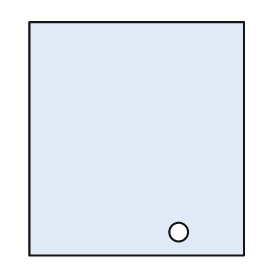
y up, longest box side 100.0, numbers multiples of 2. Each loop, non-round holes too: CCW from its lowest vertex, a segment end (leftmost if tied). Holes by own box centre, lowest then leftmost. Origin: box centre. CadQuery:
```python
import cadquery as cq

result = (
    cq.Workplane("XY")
    .moveTo(-46.0, -50.0)
    .lineTo(46.0, -50.0)
    .lineTo(46.0, 50.0)
    .lineTo(-46.0, 50.0)
    .close()
    .moveTo(18.0, -40.0)
    .circle(4.0)
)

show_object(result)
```